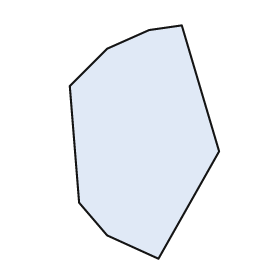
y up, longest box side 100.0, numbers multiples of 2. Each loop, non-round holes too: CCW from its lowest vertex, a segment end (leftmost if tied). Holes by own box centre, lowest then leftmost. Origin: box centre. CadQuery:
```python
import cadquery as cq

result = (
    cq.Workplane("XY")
    .moveTo(6.0, -50.0)
    .lineTo(32.0, -4.0)
    .lineTo(16.0, 50.0)
    .lineTo(2.0, 48.0)
    .lineTo(-16.0, 40.0)
    .lineTo(-32.0, 24.0)
    .lineTo(-28.0, -26.0)
    .lineTo(-16.0, -40.0)
    .close()
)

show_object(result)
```